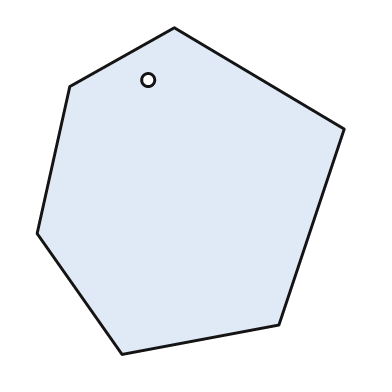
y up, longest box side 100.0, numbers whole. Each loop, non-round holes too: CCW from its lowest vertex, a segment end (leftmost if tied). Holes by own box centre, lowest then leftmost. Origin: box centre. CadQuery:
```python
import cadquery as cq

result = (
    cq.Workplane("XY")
    .moveTo(-21.0, -50.0)
    .lineTo(27.0, -41.0)
    .lineTo(47.0, 19.0)
    .lineTo(-5.0, 50.0)
    .lineTo(-37.0, 32.0)
    .lineTo(-47.0, -13.0)
    .close()
    .moveTo(-13.0, 34.0)
    .circle(2.0)
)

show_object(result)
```